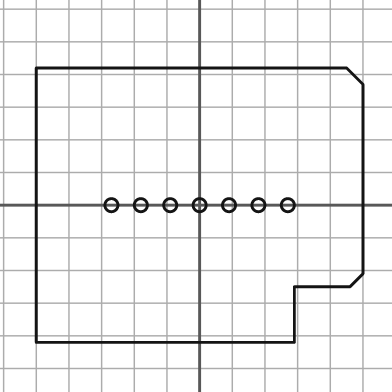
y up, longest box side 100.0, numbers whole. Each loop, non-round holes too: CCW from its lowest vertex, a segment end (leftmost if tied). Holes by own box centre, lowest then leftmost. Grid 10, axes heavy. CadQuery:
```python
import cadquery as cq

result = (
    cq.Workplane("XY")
    .moveTo(-50.0, -42.0)
    .lineTo(29.0, -42.0)
    .lineTo(29.0, -25.0)
    .lineTo(46.0, -25.0)
    .lineTo(50.0, -21.0)
    .lineTo(50.0, 37.0)
    .lineTo(45.0, 42.0)
    .lineTo(-50.0, 42.0)
    .close()
    .moveTo(-27.0, 0.0)
    .circle(2.0)
    .moveTo(-18.0, 0.0)
    .circle(2.0)
    .moveTo(-9.0, 0.0)
    .circle(2.0)
    .moveTo(0.0, 0.0)
    .circle(2.0)
    .moveTo(9.0, 0.0)
    .circle(2.0)
    .moveTo(18.0, 0.0)
    .circle(2.0)
    .moveTo(27.0, 0.0)
    .circle(2.0)
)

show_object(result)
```